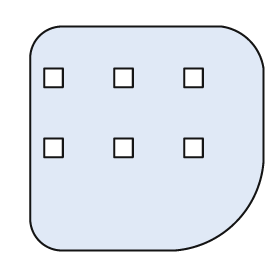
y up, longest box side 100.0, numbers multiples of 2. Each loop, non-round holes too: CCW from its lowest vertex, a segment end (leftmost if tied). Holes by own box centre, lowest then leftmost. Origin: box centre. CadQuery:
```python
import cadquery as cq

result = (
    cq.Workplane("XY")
    .moveTo(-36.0, -48.0)
    .lineTo(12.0, -48.0)
    .threePointArc((38.0, -36.0), (50.0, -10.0))
    .lineTo(50.0, 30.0)
    .threePointArc((44.0, 42.0), (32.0, 48.0))
    .lineTo(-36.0, 48.0)
    .threePointArc((-46.0, 44.0), (-50.0, 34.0))
    .lineTo(-50.0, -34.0)
    .threePointArc((-46.0, -44.0), (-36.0, -48.0))
    .close()
    .moveTo(-44.0, -8.0)
    .lineTo(-36.0, -8.0)
    .lineTo(-36.0, 0.0)
    .lineTo(-44.0, 0.0)
    .close()
    .moveTo(-14.0, -8.0)
    .lineTo(-6.0, -8.0)
    .lineTo(-6.0, 0.0)
    .lineTo(-14.0, 0.0)
    .close()
    .moveTo(16.0, -8.0)
    .lineTo(24.0, -8.0)
    .lineTo(24.0, 0.0)
    .lineTo(16.0, 0.0)
    .close()
    .moveTo(-44.0, 22.0)
    .lineTo(-36.0, 22.0)
    .lineTo(-36.0, 30.0)
    .lineTo(-44.0, 30.0)
    .close()
    .moveTo(-14.0, 22.0)
    .lineTo(-6.0, 22.0)
    .lineTo(-6.0, 30.0)
    .lineTo(-14.0, 30.0)
    .close()
    .moveTo(16.0, 22.0)
    .lineTo(24.0, 22.0)
    .lineTo(24.0, 30.0)
    .lineTo(16.0, 30.0)
    .close()
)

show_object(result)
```